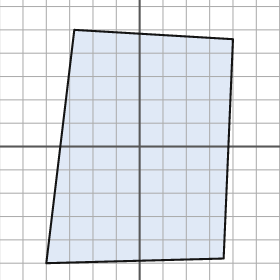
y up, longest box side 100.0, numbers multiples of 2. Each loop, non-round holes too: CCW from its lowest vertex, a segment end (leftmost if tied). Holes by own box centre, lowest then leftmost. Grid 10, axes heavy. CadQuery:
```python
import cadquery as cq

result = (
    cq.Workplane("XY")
    .moveTo(-40.0, -50.0)
    .lineTo(36.0, -48.0)
    .lineTo(40.0, 46.0)
    .lineTo(-28.0, 50.0)
    .close()
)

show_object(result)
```